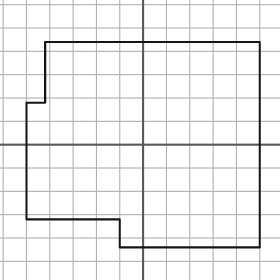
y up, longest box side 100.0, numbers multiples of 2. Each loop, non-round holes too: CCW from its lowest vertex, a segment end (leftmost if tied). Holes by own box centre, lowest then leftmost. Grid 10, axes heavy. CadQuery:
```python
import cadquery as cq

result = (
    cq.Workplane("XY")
    .moveTo(-10.0, -44.0)
    .lineTo(50.0, -44.0)
    .lineTo(50.0, 44.0)
    .lineTo(-42.0, 44.0)
    .lineTo(-42.0, 18.0)
    .lineTo(-50.0, 18.0)
    .lineTo(-50.0, -32.0)
    .lineTo(-10.0, -32.0)
    .close()
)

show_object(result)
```